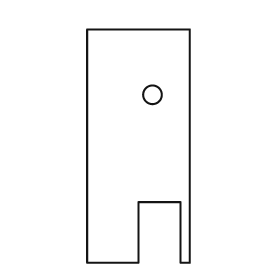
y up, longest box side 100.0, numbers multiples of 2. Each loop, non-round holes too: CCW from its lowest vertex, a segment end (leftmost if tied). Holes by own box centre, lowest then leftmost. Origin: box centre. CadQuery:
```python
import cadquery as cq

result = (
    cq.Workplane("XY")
    .moveTo(-22.0, -50.0)
    .lineTo(0.0, -50.0)
    .lineTo(0.0, -24.0)
    .lineTo(18.0, -24.0)
    .lineTo(18.0, -50.0)
    .lineTo(22.0, -50.0)
    .lineTo(22.0, 50.0)
    .lineTo(-22.0, 50.0)
    .close()
    .moveTo(6.0, 22.0)
    .circle(4.0)
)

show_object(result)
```